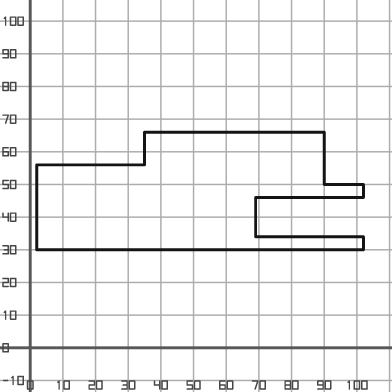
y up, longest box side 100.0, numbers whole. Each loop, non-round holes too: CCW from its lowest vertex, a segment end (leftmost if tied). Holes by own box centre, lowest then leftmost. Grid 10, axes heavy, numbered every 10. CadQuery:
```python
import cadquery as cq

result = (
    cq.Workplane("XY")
    .moveTo(2.0, 30.0)
    .lineTo(102.0, 30.0)
    .lineTo(102.0, 34.0)
    .lineTo(69.0, 34.0)
    .lineTo(69.0, 46.0)
    .lineTo(102.0, 46.0)
    .lineTo(102.0, 50.0)
    .lineTo(90.0, 50.0)
    .lineTo(90.0, 66.0)
    .lineTo(35.0, 66.0)
    .lineTo(35.0, 56.0)
    .lineTo(2.0, 56.0)
    .close()
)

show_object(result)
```